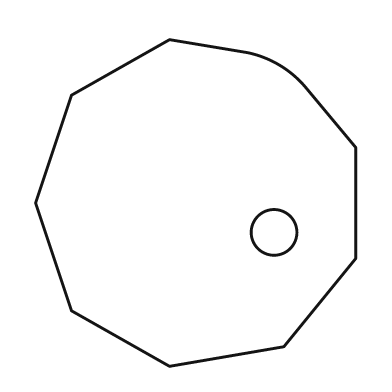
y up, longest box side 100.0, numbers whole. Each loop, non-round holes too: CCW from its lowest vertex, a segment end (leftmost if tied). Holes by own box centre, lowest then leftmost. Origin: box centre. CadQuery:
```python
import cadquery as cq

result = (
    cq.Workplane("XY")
    .moveTo(-8.0, -50.0)
    .lineTo(27.0, -44.0)
    .lineTo(49.0, -17.0)
    .lineTo(49.0, 17.0)
    .lineTo(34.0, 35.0)
    .threePointArc((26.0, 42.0), (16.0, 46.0))
    .lineTo(-8.0, 50.0)
    .lineTo(-38.0, 33.0)
    .lineTo(-49.0, 0.0)
    .lineTo(-38.0, -33.0)
    .close()
    .moveTo(24.0, -9.0)
    .circle(7.0)
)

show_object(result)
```